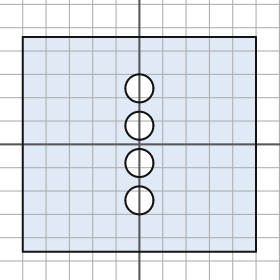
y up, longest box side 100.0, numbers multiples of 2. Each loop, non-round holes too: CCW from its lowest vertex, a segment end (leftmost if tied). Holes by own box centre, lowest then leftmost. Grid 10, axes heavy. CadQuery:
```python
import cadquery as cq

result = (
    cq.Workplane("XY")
    .moveTo(-50.0, -46.0)
    .lineTo(50.0, -46.0)
    .lineTo(50.0, 46.0)
    .lineTo(-50.0, 46.0)
    .close()
    .moveTo(0.0, -24.0)
    .circle(6.0)
    .moveTo(0.0, -8.0)
    .circle(6.0)
    .moveTo(0.0, 8.0)
    .circle(6.0)
    .moveTo(0.0, 24.0)
    .circle(6.0)
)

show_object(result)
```